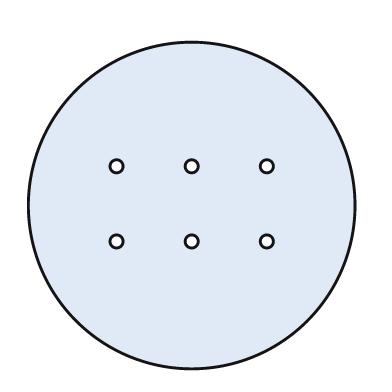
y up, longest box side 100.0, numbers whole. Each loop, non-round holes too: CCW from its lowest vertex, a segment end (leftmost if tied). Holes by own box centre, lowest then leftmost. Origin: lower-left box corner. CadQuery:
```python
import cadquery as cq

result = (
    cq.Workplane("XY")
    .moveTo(50.0, 50.0)
    .circle(50.0)
    .moveTo(27.0, 39.0)
    .circle(2.0)
    .moveTo(50.0, 39.0)
    .circle(2.0)
    .moveTo(73.0, 39.0)
    .circle(2.0)
    .moveTo(27.0, 62.0)
    .circle(2.0)
    .moveTo(50.0, 62.0)
    .circle(2.0)
    .moveTo(73.0, 62.0)
    .circle(2.0)
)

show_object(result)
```